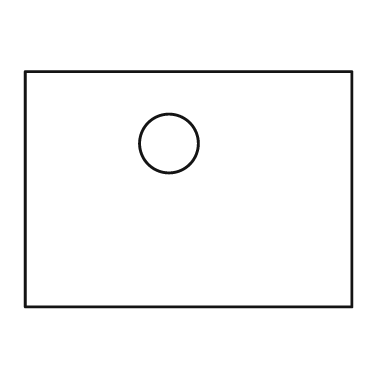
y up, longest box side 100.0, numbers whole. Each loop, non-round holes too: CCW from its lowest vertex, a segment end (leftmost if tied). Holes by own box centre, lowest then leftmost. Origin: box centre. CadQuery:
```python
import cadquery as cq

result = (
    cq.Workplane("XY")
    .moveTo(-50.0, -36.0)
    .lineTo(50.0, -36.0)
    .lineTo(50.0, 36.0)
    .lineTo(-50.0, 36.0)
    .close()
    .moveTo(-6.0, 14.0)
    .circle(9.0)
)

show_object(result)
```